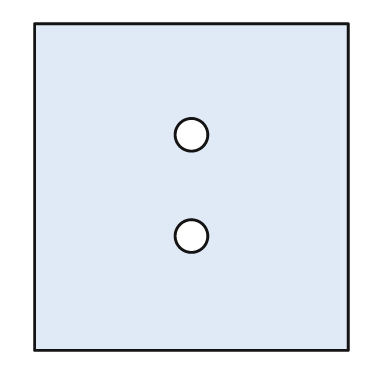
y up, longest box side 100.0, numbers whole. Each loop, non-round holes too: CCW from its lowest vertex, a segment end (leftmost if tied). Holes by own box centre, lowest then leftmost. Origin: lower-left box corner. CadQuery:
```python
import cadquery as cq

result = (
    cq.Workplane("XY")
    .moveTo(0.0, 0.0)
    .lineTo(96.0, 0.0)
    .lineTo(96.0, 100.0)
    .lineTo(0.0, 100.0)
    .close()
    .moveTo(48.0, 35.0)
    .circle(5.0)
    .moveTo(48.0, 66.0)
    .circle(5.0)
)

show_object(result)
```